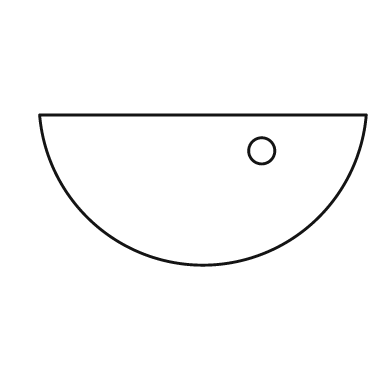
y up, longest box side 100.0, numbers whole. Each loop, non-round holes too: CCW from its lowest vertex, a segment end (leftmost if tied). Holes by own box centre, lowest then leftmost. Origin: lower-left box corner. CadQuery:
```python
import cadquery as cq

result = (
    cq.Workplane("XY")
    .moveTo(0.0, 46.0)
    .threePointArc((50.0, 0.0), (100.0, 46.0))
    .close()
    .moveTo(68.0, 35.0)
    .circle(4.0)
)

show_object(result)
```